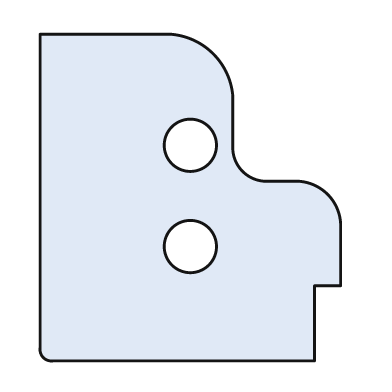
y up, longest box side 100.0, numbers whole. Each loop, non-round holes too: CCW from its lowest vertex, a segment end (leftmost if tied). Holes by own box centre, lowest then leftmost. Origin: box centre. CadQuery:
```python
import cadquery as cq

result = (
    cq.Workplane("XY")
    .moveTo(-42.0, -50.0)
    .lineTo(38.0, -50.0)
    .lineTo(38.0, -27.0)
    .lineTo(46.0, -27.0)
    .lineTo(46.0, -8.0)
    .threePointArc((42.0, 1.0), (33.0, 5.0))
    .lineTo(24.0, 5.0)
    .threePointArc((16.0, 8.0), (13.0, 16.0))
    .lineTo(13.0, 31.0)
    .threePointArc((7.0, 44.0), (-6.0, 50.0))
    .lineTo(-46.0, 50.0)
    .lineTo(-46.0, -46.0)
    .threePointArc((-45.0, -49.0), (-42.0, -50.0))
    .close()
    .moveTo(0.0, -15.0)
    .circle(8.0)
    .moveTo(0.0, 16.0)
    .circle(8.0)
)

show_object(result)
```